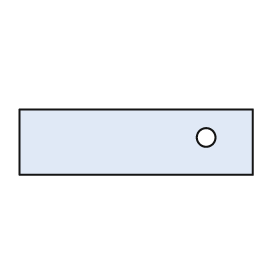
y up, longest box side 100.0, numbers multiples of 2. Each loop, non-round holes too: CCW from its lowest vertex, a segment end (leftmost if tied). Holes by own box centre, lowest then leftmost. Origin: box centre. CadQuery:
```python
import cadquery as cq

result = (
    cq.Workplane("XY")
    .moveTo(-50.0, -14.0)
    .lineTo(50.0, -14.0)
    .lineTo(50.0, 14.0)
    .lineTo(-50.0, 14.0)
    .close()
    .moveTo(30.0, 2.0)
    .circle(4.0)
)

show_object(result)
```